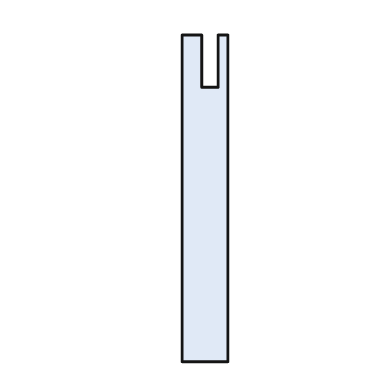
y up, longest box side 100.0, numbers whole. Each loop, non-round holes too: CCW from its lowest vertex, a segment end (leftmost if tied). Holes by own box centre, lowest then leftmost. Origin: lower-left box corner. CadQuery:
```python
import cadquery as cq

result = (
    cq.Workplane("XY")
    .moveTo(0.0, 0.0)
    .lineTo(14.0, 0.0)
    .lineTo(14.0, 100.0)
    .lineTo(11.0, 100.0)
    .lineTo(11.0, 84.0)
    .lineTo(6.0, 84.0)
    .lineTo(6.0, 100.0)
    .lineTo(0.0, 100.0)
    .close()
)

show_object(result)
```